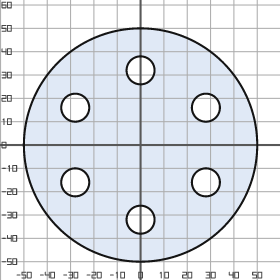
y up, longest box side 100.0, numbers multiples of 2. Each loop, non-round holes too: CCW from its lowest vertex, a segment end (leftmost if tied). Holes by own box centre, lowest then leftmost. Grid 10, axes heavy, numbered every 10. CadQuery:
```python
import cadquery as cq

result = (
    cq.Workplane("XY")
    .moveTo(0.0, 0.0)
    .circle(50.0)
    .moveTo(0.0, -32.0)
    .circle(6.0)
    .moveTo(-28.0, -16.0)
    .circle(6.0)
    .moveTo(28.0, -16.0)
    .circle(6.0)
    .moveTo(-28.0, 16.0)
    .circle(6.0)
    .moveTo(28.0, 16.0)
    .circle(6.0)
    .moveTo(0.0, 32.0)
    .circle(6.0)
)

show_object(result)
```